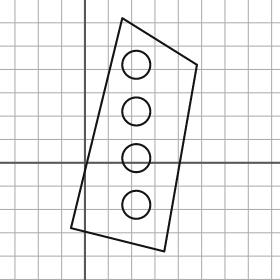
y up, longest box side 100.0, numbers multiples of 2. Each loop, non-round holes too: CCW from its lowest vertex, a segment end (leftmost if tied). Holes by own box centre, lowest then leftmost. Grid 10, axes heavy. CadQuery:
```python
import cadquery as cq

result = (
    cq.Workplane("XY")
    .moveTo(34.0, -38.0)
    .lineTo(48.0, 42.0)
    .lineTo(16.0, 62.0)
    .lineTo(-6.0, -28.0)
    .close()
    .moveTo(22.0, -18.0)
    .circle(6.0)
    .moveTo(22.0, 2.0)
    .circle(6.0)
    .moveTo(22.0, 22.0)
    .circle(6.0)
    .moveTo(22.0, 42.0)
    .circle(6.0)
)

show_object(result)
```